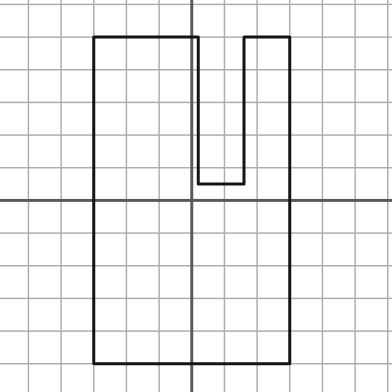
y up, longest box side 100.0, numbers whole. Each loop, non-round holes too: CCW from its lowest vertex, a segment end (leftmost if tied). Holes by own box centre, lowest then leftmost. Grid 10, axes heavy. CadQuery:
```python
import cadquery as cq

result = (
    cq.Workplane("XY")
    .moveTo(-30.0, -50.0)
    .lineTo(30.0, -50.0)
    .lineTo(30.0, 50.0)
    .lineTo(16.0, 50.0)
    .lineTo(16.0, 5.0)
    .lineTo(2.0, 5.0)
    .lineTo(2.0, 50.0)
    .lineTo(-30.0, 50.0)
    .close()
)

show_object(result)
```